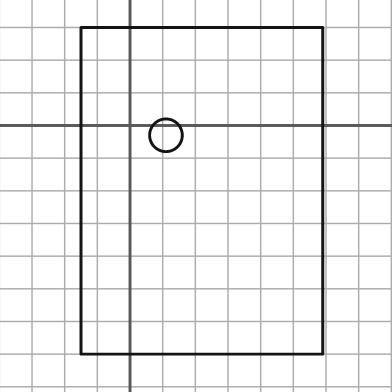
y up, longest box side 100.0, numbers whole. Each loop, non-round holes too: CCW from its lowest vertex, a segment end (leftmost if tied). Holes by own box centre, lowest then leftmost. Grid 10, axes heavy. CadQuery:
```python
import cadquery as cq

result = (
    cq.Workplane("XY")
    .moveTo(-15.0, -70.0)
    .lineTo(59.0, -70.0)
    .lineTo(59.0, 30.0)
    .lineTo(-15.0, 30.0)
    .close()
    .moveTo(11.0, -3.0)
    .circle(5.0)
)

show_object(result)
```